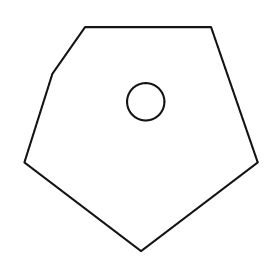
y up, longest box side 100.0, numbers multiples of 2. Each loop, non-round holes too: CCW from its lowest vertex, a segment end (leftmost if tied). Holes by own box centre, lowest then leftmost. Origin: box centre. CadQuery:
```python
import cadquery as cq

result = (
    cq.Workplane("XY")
    .moveTo(0.0, -48.0)
    .lineTo(50.0, -10.0)
    .lineTo(30.0, 48.0)
    .lineTo(-24.0, 48.0)
    .lineTo(-38.0, 28.0)
    .lineTo(-50.0, -10.0)
    .close()
    .moveTo(2.0, 16.0)
    .circle(8.0)
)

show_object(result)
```